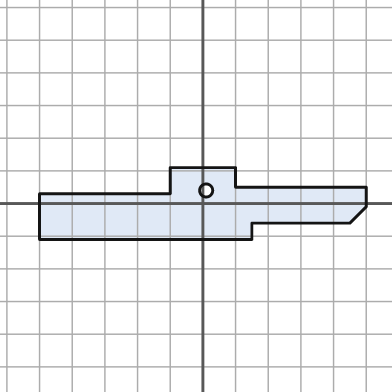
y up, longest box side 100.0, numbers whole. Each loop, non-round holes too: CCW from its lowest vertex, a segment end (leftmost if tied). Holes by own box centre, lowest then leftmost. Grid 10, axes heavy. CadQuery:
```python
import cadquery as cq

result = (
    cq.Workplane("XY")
    .moveTo(-50.0, -11.0)
    .lineTo(15.0, -11.0)
    .lineTo(15.0, -6.0)
    .lineTo(45.0, -6.0)
    .lineTo(50.0, -1.0)
    .lineTo(50.0, 5.0)
    .lineTo(10.0, 5.0)
    .lineTo(10.0, 11.0)
    .lineTo(-10.0, 11.0)
    .lineTo(-10.0, 3.0)
    .lineTo(-50.0, 3.0)
    .close()
    .moveTo(1.0, 4.0)
    .circle(2.0)
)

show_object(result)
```